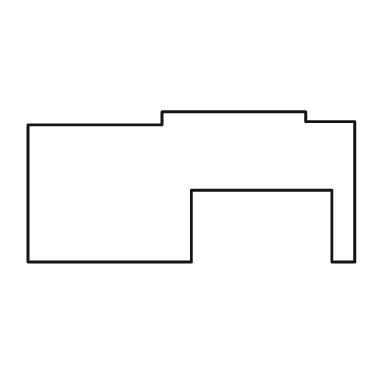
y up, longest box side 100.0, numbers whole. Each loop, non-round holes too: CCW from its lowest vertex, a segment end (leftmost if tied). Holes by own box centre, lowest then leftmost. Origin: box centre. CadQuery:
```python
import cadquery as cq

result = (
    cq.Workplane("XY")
    .moveTo(-50.0, -23.0)
    .lineTo(0.0, -23.0)
    .lineTo(0.0, -1.0)
    .lineTo(43.0, -1.0)
    .lineTo(43.0, -23.0)
    .lineTo(50.0, -23.0)
    .lineTo(50.0, 20.0)
    .lineTo(35.0, 20.0)
    .lineTo(35.0, 23.0)
    .lineTo(-9.0, 23.0)
    .lineTo(-9.0, 19.0)
    .lineTo(-50.0, 19.0)
    .close()
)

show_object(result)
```